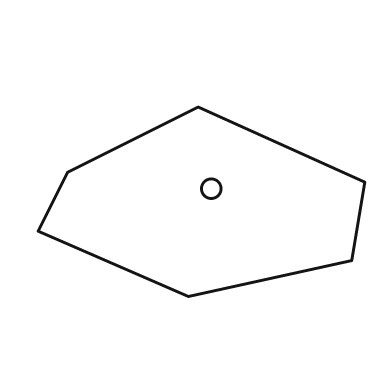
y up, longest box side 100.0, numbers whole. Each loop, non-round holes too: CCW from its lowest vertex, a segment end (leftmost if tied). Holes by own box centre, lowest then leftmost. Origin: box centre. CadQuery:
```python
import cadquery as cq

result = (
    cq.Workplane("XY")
    .moveTo(-4.0, -29.0)
    .lineTo(46.0, -18.0)
    .lineTo(50.0, 6.0)
    .lineTo(-1.0, 29.0)
    .lineTo(-41.0, 9.0)
    .lineTo(-50.0, -9.0)
    .close()
    .moveTo(3.0, 4.0)
    .circle(3.0)
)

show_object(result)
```